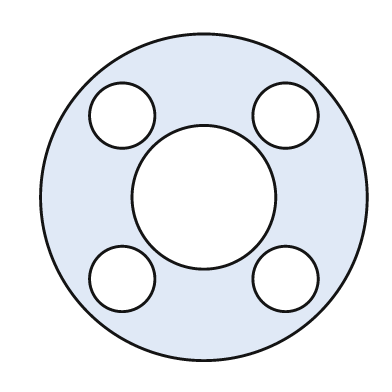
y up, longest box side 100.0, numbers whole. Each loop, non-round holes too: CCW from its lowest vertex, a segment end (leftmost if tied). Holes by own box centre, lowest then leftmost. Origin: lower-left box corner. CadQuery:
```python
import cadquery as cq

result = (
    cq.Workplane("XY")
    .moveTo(50.0, 50.0)
    .circle(50.0)
    .moveTo(25.0, 25.0)
    .circle(10.0)
    .moveTo(75.0, 25.0)
    .circle(10.0)
    .moveTo(50.0, 50.0)
    .circle(22.0)
    .moveTo(25.0, 75.0)
    .circle(10.0)
    .moveTo(75.0, 75.0)
    .circle(10.0)
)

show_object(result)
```